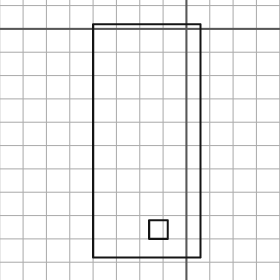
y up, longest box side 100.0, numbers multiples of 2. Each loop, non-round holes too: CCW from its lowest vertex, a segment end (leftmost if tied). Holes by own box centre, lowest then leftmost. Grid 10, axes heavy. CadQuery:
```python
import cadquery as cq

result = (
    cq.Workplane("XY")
    .moveTo(-40.0, -98.0)
    .lineTo(6.0, -98.0)
    .lineTo(6.0, 2.0)
    .lineTo(-40.0, 2.0)
    .close()
    .moveTo(-16.0, -90.0)
    .lineTo(-8.0, -90.0)
    .lineTo(-8.0, -82.0)
    .lineTo(-16.0, -82.0)
    .close()
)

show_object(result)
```